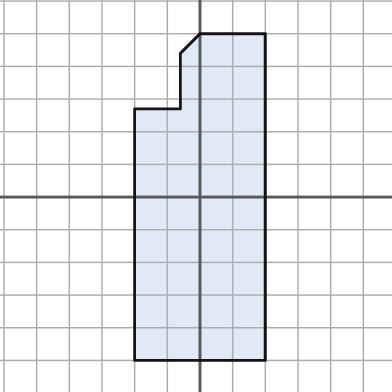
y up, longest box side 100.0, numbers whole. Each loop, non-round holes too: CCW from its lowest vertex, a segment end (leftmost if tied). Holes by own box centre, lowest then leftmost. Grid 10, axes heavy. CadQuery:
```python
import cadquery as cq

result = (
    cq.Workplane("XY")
    .moveTo(-20.0, -50.0)
    .lineTo(20.0, -50.0)
    .lineTo(20.0, 50.0)
    .lineTo(0.0, 50.0)
    .lineTo(-6.0, 44.0)
    .lineTo(-6.0, 27.0)
    .lineTo(-20.0, 27.0)
    .close()
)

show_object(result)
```